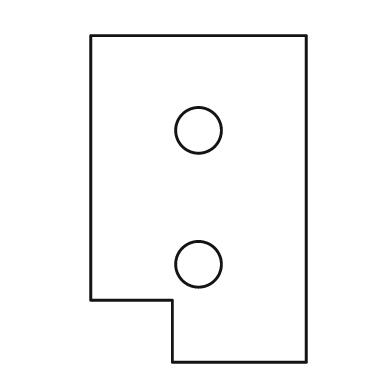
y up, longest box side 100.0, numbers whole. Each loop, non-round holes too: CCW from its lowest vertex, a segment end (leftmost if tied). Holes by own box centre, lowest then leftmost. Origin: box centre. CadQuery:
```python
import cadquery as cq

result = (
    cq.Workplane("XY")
    .moveTo(-8.0, -50.0)
    .lineTo(33.0, -50.0)
    .lineTo(33.0, 50.0)
    .lineTo(-33.0, 50.0)
    .lineTo(-33.0, -31.0)
    .lineTo(-8.0, -31.0)
    .close()
    .moveTo(0.0, -20.0)
    .circle(7.0)
    .moveTo(0.0, 21.0)
    .circle(7.0)
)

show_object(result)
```